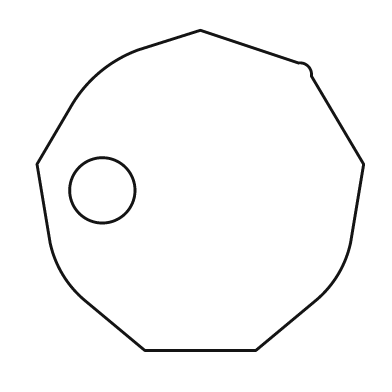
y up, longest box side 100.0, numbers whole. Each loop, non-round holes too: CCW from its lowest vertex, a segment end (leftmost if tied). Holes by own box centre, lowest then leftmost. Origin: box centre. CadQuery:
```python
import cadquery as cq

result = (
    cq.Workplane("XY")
    .moveTo(-17.0, -49.0)
    .lineTo(17.0, -49.0)
    .lineTo(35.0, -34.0)
    .threePointArc((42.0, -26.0), (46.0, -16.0))
    .lineTo(50.0, 8.0)
    .lineTo(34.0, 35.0)
    .threePointArc((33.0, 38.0), (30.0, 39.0))
    .lineTo(0.0, 49.0)
    .lineTo(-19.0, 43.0)
    .threePointArc((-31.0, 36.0), (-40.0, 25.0))
    .lineTo(-50.0, 8.0)
    .lineTo(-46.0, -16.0)
    .threePointArc((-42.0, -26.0), (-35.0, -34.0))
    .close()
    .moveTo(-30.0, 0.0)
    .circle(10.0)
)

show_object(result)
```